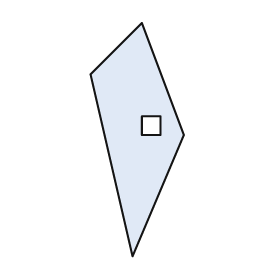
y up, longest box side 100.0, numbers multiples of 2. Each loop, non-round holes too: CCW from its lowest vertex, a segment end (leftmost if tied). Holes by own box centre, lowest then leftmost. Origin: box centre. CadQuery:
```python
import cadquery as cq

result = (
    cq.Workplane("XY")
    .moveTo(-2.0, -50.0)
    .lineTo(20.0, 2.0)
    .lineTo(2.0, 50.0)
    .lineTo(-20.0, 28.0)
    .close()
    .moveTo(2.0, 2.0)
    .lineTo(10.0, 2.0)
    .lineTo(10.0, 10.0)
    .lineTo(2.0, 10.0)
    .close()
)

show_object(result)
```